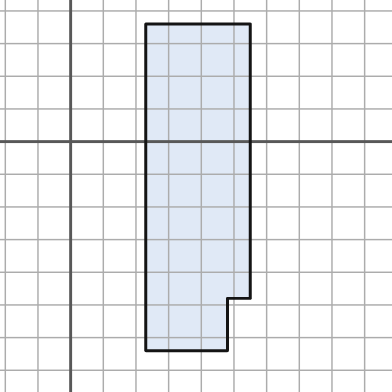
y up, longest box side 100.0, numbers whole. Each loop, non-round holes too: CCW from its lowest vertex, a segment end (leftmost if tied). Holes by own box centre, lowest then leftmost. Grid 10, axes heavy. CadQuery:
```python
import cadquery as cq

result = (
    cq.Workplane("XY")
    .moveTo(23.0, -64.0)
    .lineTo(48.0, -64.0)
    .lineTo(48.0, -48.0)
    .lineTo(55.0, -48.0)
    .lineTo(55.0, 36.0)
    .lineTo(23.0, 36.0)
    .close()
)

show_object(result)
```